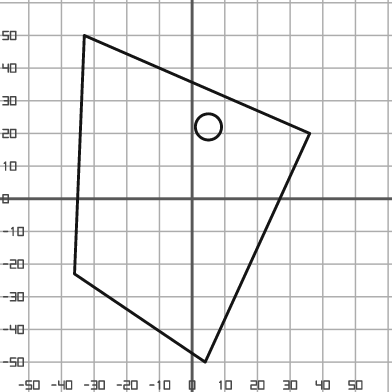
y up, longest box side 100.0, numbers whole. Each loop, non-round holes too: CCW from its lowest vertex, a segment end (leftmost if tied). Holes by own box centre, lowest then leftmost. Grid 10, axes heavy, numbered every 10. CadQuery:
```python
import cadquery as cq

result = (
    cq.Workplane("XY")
    .moveTo(4.0, -50.0)
    .lineTo(36.0, 20.0)
    .lineTo(-33.0, 50.0)
    .lineTo(-36.0, -23.0)
    .close()
    .moveTo(5.0, 22.0)
    .circle(4.0)
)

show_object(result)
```